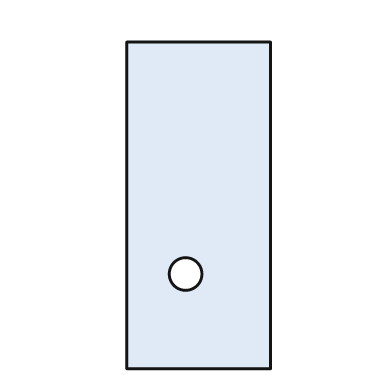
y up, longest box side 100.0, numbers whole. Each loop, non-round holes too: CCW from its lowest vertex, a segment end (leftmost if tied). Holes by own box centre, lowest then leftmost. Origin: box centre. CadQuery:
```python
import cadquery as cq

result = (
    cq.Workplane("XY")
    .moveTo(-22.0, -50.0)
    .lineTo(22.0, -50.0)
    .lineTo(22.0, 50.0)
    .lineTo(-22.0, 50.0)
    .close()
    .moveTo(-4.0, -21.0)
    .circle(5.0)
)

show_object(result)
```